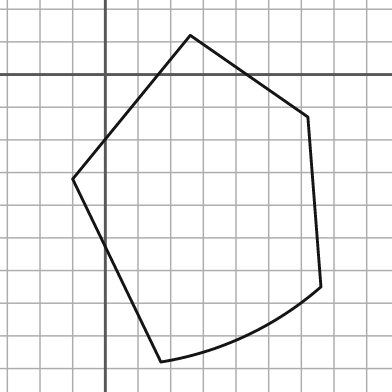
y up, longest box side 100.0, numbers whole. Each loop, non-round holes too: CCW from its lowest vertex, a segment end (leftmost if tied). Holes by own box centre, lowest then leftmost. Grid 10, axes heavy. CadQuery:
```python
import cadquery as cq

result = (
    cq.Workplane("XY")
    .moveTo(17.0, -88.0)
    .threePointArc((43.0, -80.0), (66.0, -65.0))
    .lineTo(62.0, -13.0)
    .lineTo(26.0, 12.0)
    .lineTo(-10.0, -32.0)
    .close()
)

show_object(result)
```